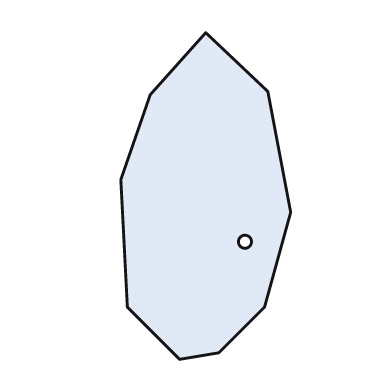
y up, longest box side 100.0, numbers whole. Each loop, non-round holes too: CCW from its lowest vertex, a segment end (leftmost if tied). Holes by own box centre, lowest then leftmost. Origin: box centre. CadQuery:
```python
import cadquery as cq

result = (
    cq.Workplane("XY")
    .moveTo(-8.0, -50.0)
    .lineTo(4.0, -48.0)
    .lineTo(18.0, -34.0)
    .lineTo(26.0, -5.0)
    .lineTo(19.0, 32.0)
    .lineTo(0.0, 50.0)
    .lineTo(-17.0, 31.0)
    .lineTo(-26.0, 5.0)
    .lineTo(-24.0, -34.0)
    .close()
    .moveTo(12.0, -14.0)
    .circle(2.0)
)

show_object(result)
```